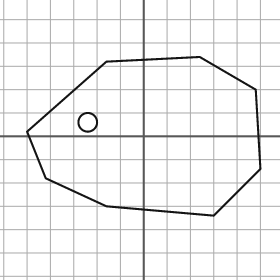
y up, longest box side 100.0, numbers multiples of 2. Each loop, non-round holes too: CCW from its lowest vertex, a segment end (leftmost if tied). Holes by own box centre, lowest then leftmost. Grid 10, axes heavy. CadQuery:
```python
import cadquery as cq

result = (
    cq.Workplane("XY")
    .moveTo(30.0, -34.0)
    .lineTo(50.0, -14.0)
    .lineTo(48.0, 20.0)
    .lineTo(24.0, 34.0)
    .lineTo(-16.0, 32.0)
    .lineTo(-50.0, 2.0)
    .lineTo(-42.0, -18.0)
    .lineTo(-16.0, -30.0)
    .close()
    .moveTo(-24.0, 6.0)
    .circle(4.0)
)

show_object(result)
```